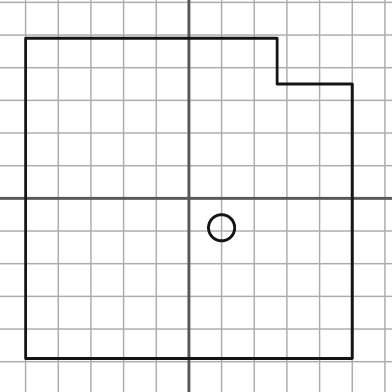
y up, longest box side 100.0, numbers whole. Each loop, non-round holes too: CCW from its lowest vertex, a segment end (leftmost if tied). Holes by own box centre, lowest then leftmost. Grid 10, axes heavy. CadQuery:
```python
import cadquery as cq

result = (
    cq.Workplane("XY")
    .moveTo(-50.0, -49.0)
    .lineTo(50.0, -49.0)
    .lineTo(50.0, 35.0)
    .lineTo(27.0, 35.0)
    .lineTo(27.0, 49.0)
    .lineTo(-50.0, 49.0)
    .close()
    .moveTo(10.0, -9.0)
    .circle(4.0)
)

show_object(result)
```